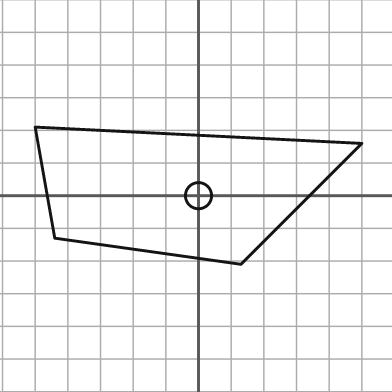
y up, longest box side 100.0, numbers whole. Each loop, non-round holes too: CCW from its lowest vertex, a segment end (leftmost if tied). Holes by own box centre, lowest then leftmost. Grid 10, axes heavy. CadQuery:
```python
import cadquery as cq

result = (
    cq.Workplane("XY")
    .moveTo(13.0, -21.0)
    .lineTo(50.0, 16.0)
    .lineTo(-50.0, 21.0)
    .lineTo(-44.0, -13.0)
    .close()
    .moveTo(0.0, 0.0)
    .circle(4.0)
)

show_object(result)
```